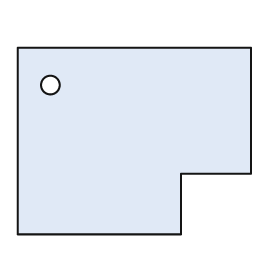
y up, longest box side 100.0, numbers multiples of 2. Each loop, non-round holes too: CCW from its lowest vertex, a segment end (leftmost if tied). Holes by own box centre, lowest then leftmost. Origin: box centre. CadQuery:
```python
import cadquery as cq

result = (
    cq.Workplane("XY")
    .moveTo(-50.0, -40.0)
    .lineTo(20.0, -40.0)
    .lineTo(20.0, -14.0)
    .lineTo(50.0, -14.0)
    .lineTo(50.0, 40.0)
    .lineTo(-50.0, 40.0)
    .close()
    .moveTo(-36.0, 24.0)
    .circle(4.0)
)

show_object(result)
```